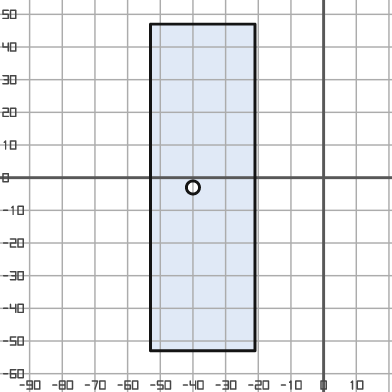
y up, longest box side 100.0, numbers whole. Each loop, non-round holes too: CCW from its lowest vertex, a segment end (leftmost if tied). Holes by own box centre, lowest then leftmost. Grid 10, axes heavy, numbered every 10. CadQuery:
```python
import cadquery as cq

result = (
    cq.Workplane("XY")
    .moveTo(-53.0, -53.0)
    .lineTo(-21.0, -53.0)
    .lineTo(-21.0, 47.0)
    .lineTo(-53.0, 47.0)
    .close()
    .moveTo(-40.0, -3.0)
    .circle(2.0)
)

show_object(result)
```